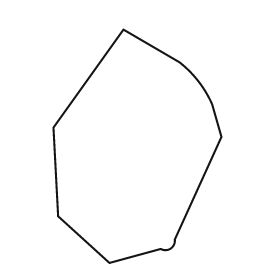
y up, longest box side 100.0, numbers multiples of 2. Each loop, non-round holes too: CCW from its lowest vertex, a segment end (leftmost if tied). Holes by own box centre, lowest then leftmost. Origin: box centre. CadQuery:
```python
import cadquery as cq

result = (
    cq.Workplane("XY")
    .moveTo(-12.0, -50.0)
    .lineTo(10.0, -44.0)
    .threePointArc((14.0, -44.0), (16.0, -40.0))
    .lineTo(36.0, 4.0)
    .lineTo(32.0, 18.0)
    .threePointArc((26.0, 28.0), (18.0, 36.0))
    .lineTo(-6.0, 50.0)
    .lineTo(-36.0, 8.0)
    .lineTo(-34.0, -30.0)
    .close()
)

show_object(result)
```